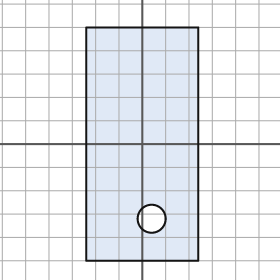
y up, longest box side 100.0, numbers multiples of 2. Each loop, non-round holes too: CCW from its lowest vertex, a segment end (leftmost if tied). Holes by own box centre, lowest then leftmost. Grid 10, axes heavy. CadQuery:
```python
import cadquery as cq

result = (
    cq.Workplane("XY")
    .moveTo(-24.0, -50.0)
    .lineTo(24.0, -50.0)
    .lineTo(24.0, 50.0)
    .lineTo(-24.0, 50.0)
    .close()
    .moveTo(4.0, -32.0)
    .circle(6.0)
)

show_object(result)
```